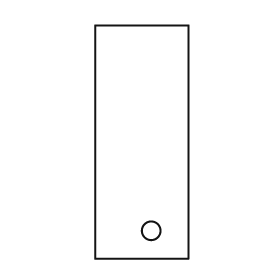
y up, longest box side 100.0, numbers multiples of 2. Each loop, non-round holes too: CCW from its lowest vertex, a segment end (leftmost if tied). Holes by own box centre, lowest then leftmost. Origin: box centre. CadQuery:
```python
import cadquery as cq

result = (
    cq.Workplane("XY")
    .moveTo(-20.0, -50.0)
    .lineTo(20.0, -50.0)
    .lineTo(20.0, 50.0)
    .lineTo(-20.0, 50.0)
    .close()
    .moveTo(4.0, -38.0)
    .circle(4.0)
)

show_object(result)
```